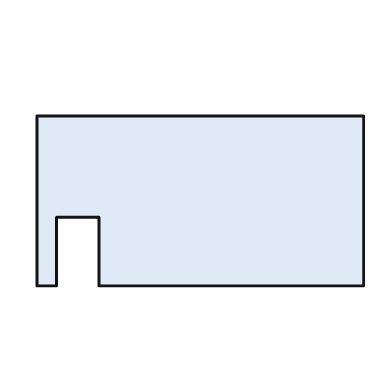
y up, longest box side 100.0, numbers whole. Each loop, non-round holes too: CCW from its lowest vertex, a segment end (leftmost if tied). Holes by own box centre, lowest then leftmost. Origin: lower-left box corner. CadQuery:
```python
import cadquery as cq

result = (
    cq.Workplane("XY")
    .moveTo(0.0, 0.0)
    .lineTo(6.0, 0.0)
    .lineTo(6.0, 21.0)
    .lineTo(19.0, 21.0)
    .lineTo(19.0, 0.0)
    .lineTo(100.0, 0.0)
    .lineTo(100.0, 52.0)
    .lineTo(0.0, 52.0)
    .close()
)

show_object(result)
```